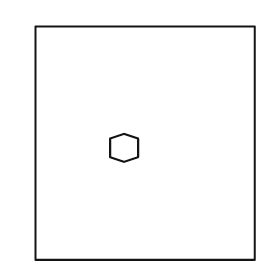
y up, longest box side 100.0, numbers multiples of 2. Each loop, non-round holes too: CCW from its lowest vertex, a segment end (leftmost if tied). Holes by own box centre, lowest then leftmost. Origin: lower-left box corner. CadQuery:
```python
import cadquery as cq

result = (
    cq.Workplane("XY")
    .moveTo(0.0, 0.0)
    .lineTo(94.0, 0.0)
    .lineTo(94.0, 100.0)
    .lineTo(0.0, 100.0)
    .close()
    .moveTo(38.0, 42.0)
    .lineTo(44.0, 44.0)
    .lineTo(44.0, 52.0)
    .lineTo(38.0, 54.0)
    .lineTo(32.0, 52.0)
    .lineTo(32.0, 44.0)
    .close()
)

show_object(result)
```